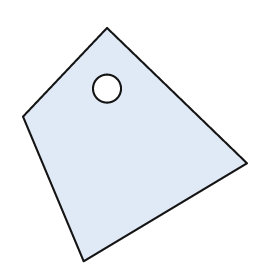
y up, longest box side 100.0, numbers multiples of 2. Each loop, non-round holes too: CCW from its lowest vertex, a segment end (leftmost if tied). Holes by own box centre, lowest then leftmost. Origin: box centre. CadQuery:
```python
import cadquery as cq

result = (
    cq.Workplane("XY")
    .moveTo(-22.0, -50.0)
    .lineTo(48.0, -8.0)
    .lineTo(-12.0, 50.0)
    .lineTo(-48.0, 12.0)
    .close()
    .moveTo(-12.0, 24.0)
    .circle(6.0)
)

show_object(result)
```